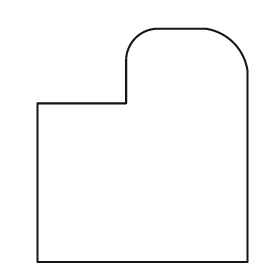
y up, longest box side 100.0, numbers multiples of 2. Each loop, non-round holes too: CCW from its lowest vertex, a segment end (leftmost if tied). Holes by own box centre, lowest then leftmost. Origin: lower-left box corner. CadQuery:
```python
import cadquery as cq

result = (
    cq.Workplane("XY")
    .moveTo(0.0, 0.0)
    .lineTo(90.0, 0.0)
    .lineTo(90.0, 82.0)
    .threePointArc((84.0, 94.0), (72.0, 100.0))
    .lineTo(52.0, 100.0)
    .threePointArc((42.0, 96.0), (38.0, 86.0))
    .lineTo(38.0, 68.0)
    .lineTo(0.0, 68.0)
    .close()
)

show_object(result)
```